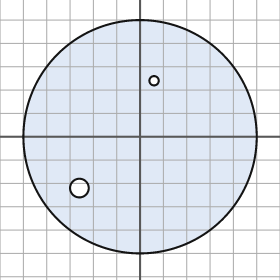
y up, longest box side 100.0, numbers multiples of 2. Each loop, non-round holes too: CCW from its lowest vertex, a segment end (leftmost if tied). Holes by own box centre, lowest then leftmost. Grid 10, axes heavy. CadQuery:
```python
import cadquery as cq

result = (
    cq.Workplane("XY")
    .moveTo(0.0, 0.0)
    .circle(50.0)
    .moveTo(-26.0, -22.0)
    .circle(4.0)
    .moveTo(6.0, 24.0)
    .circle(2.0)
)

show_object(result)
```